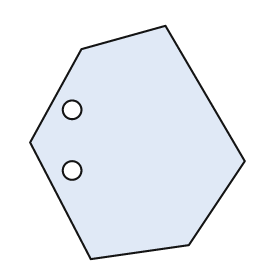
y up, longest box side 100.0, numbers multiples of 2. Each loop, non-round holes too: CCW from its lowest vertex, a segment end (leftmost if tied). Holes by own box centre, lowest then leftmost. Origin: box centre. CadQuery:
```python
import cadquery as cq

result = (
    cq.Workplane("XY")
    .moveTo(-20.0, -50.0)
    .lineTo(22.0, -44.0)
    .lineTo(46.0, -8.0)
    .lineTo(12.0, 50.0)
    .lineTo(-24.0, 40.0)
    .lineTo(-46.0, 0.0)
    .close()
    .moveTo(-28.0, -12.0)
    .circle(4.0)
    .moveTo(-28.0, 14.0)
    .circle(4.0)
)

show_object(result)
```